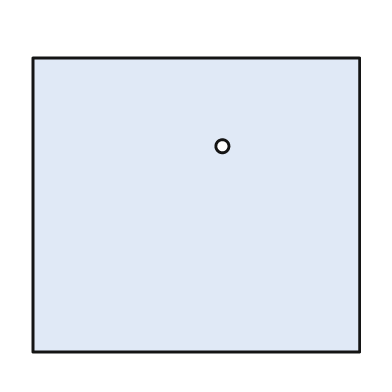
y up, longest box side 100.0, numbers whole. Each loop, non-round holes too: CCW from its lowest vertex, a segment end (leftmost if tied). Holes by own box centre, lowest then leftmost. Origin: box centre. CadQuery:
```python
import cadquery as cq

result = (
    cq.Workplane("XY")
    .moveTo(-50.0, -45.0)
    .lineTo(50.0, -45.0)
    .lineTo(50.0, 45.0)
    .lineTo(-50.0, 45.0)
    .close()
    .moveTo(8.0, 18.0)
    .circle(2.0)
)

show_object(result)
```